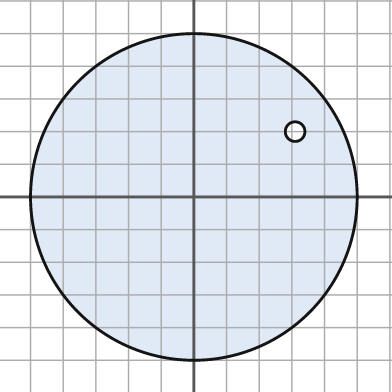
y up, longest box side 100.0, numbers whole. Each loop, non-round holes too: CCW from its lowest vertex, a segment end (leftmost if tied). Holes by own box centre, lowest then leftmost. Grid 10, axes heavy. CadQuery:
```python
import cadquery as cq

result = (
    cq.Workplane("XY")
    .moveTo(0.0, 0.0)
    .circle(50.0)
    .moveTo(31.0, 20.0)
    .circle(3.0)
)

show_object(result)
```